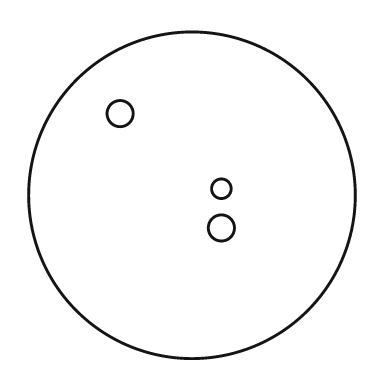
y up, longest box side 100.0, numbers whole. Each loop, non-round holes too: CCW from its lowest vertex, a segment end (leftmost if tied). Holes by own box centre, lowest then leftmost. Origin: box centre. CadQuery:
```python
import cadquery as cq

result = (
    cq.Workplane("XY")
    .moveTo(0.0, 0.0)
    .circle(50.0)
    .moveTo(9.0, -10.0)
    .circle(4.0)
    .moveTo(9.0, 2.0)
    .circle(3.0)
    .moveTo(-22.0, 25.0)
    .circle(4.0)
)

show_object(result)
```